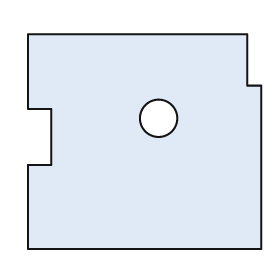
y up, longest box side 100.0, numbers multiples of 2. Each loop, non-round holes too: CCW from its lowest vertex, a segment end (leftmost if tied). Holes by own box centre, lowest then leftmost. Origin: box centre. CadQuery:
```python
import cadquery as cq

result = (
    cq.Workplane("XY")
    .moveTo(-50.0, -46.0)
    .lineTo(50.0, -46.0)
    .lineTo(50.0, 24.0)
    .lineTo(44.0, 24.0)
    .lineTo(44.0, 46.0)
    .lineTo(-50.0, 46.0)
    .lineTo(-50.0, 14.0)
    .lineTo(-40.0, 14.0)
    .lineTo(-40.0, -10.0)
    .lineTo(-50.0, -10.0)
    .close()
    .moveTo(6.0, 10.0)
    .circle(8.0)
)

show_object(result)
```